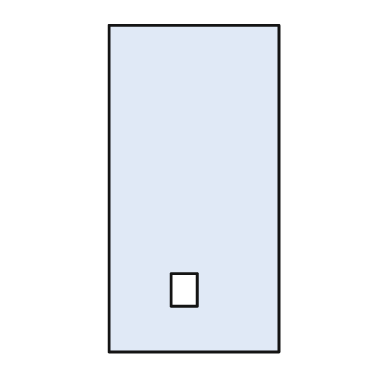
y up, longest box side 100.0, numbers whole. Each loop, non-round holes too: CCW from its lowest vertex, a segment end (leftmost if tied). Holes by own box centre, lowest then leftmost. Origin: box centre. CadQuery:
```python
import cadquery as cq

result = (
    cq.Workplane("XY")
    .moveTo(-26.0, -50.0)
    .lineTo(26.0, -50.0)
    .lineTo(26.0, 50.0)
    .lineTo(-26.0, 50.0)
    .close()
    .moveTo(-7.0, -36.0)
    .lineTo(1.0, -36.0)
    .lineTo(1.0, -26.0)
    .lineTo(-7.0, -26.0)
    .close()
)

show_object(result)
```